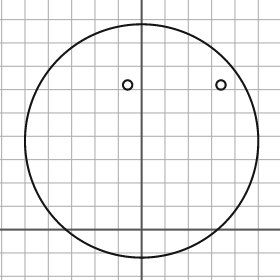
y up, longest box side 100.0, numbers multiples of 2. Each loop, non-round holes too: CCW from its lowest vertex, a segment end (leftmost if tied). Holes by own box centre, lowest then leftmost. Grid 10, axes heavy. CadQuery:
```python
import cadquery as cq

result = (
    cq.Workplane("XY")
    .moveTo(0.0, 38.0)
    .circle(50.0)
    .moveTo(-6.0, 62.0)
    .circle(2.0)
    .moveTo(34.0, 62.0)
    .circle(2.0)
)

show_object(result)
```